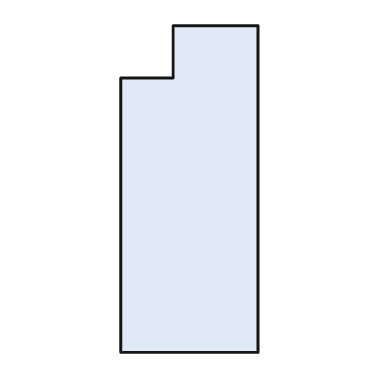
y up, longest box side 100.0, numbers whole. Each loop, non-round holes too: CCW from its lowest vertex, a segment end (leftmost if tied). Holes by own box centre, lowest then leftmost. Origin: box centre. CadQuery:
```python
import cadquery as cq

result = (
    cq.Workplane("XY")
    .moveTo(-21.0, -50.0)
    .lineTo(21.0, -50.0)
    .lineTo(21.0, 50.0)
    .lineTo(-5.0, 50.0)
    .lineTo(-5.0, 34.0)
    .lineTo(-21.0, 34.0)
    .close()
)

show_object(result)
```